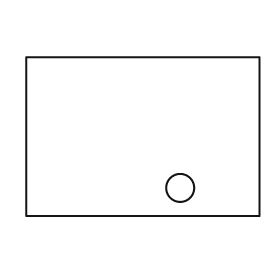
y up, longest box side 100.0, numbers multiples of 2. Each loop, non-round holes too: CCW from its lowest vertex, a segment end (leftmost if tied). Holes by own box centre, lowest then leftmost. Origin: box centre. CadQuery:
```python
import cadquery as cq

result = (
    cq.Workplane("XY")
    .moveTo(-50.0, -34.0)
    .lineTo(50.0, -34.0)
    .lineTo(50.0, 34.0)
    .lineTo(-50.0, 34.0)
    .close()
    .moveTo(16.0, -22.0)
    .circle(6.0)
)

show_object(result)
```